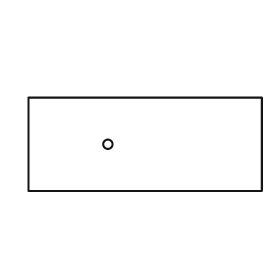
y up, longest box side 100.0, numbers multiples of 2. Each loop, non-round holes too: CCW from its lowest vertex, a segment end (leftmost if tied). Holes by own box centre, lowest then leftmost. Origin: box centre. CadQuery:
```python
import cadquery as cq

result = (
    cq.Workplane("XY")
    .moveTo(-50.0, -20.0)
    .lineTo(50.0, -20.0)
    .lineTo(50.0, 20.0)
    .lineTo(-50.0, 20.0)
    .close()
    .moveTo(-16.0, 0.0)
    .circle(2.0)
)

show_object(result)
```